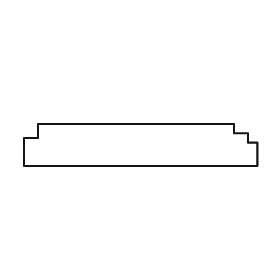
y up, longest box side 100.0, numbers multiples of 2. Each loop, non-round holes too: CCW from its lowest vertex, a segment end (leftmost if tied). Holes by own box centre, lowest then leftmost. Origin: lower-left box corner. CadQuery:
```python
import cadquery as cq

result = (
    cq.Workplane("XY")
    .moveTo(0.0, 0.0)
    .lineTo(100.0, 0.0)
    .lineTo(100.0, 10.0)
    .lineTo(96.0, 10.0)
    .lineTo(96.0, 14.0)
    .lineTo(90.0, 14.0)
    .lineTo(90.0, 18.0)
    .lineTo(6.0, 18.0)
    .lineTo(6.0, 12.0)
    .lineTo(0.0, 12.0)
    .close()
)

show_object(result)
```